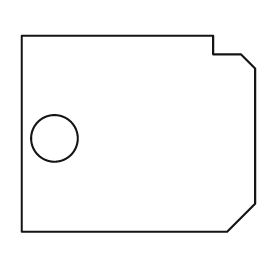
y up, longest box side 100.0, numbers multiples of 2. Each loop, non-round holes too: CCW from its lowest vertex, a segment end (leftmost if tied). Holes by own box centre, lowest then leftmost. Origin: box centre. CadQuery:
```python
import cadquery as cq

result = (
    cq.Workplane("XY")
    .moveTo(-50.0, -42.0)
    .lineTo(38.0, -42.0)
    .lineTo(50.0, -30.0)
    .lineTo(50.0, 28.0)
    .lineTo(44.0, 34.0)
    .lineTo(32.0, 34.0)
    .lineTo(32.0, 42.0)
    .lineTo(-50.0, 42.0)
    .close()
    .moveTo(-36.0, -2.0)
    .circle(10.0)
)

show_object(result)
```